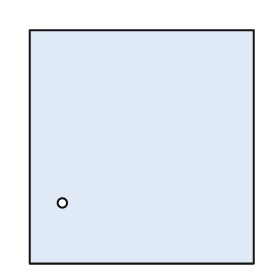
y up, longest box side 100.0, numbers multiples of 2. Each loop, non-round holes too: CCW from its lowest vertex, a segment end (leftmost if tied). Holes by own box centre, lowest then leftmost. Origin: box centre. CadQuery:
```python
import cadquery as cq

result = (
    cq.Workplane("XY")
    .moveTo(-48.0, -50.0)
    .lineTo(48.0, -50.0)
    .lineTo(48.0, 50.0)
    .lineTo(-48.0, 50.0)
    .close()
    .moveTo(-34.0, -24.0)
    .circle(2.0)
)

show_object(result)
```